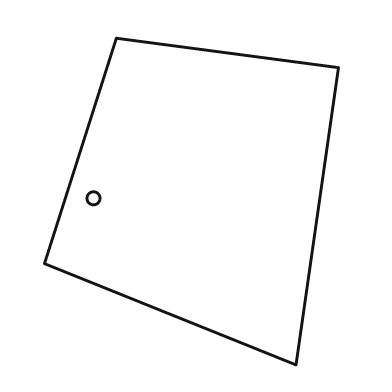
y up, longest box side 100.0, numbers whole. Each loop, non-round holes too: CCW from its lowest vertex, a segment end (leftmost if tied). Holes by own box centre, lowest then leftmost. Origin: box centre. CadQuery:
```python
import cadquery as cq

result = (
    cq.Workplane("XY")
    .moveTo(32.0, -50.0)
    .lineTo(45.0, 41.0)
    .lineTo(-23.0, 50.0)
    .lineTo(-45.0, -19.0)
    .close()
    .moveTo(-30.0, 1.0)
    .circle(2.0)
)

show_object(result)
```